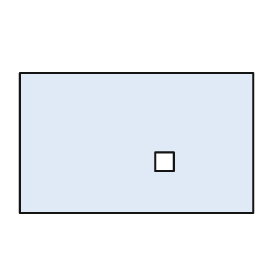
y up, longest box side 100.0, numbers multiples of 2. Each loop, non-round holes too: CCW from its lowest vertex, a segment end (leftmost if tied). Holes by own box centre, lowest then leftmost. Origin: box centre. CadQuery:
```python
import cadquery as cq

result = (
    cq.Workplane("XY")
    .moveTo(-50.0, -30.0)
    .lineTo(50.0, -30.0)
    .lineTo(50.0, 30.0)
    .lineTo(-50.0, 30.0)
    .close()
    .moveTo(8.0, -12.0)
    .lineTo(16.0, -12.0)
    .lineTo(16.0, -4.0)
    .lineTo(8.0, -4.0)
    .close()
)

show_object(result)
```